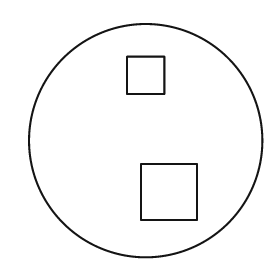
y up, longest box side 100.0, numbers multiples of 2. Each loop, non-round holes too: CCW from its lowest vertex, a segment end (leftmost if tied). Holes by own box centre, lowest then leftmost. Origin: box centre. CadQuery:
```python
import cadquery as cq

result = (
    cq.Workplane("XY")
    .moveTo(0.0, 0.0)
    .circle(50.0)
    .moveTo(-2.0, -34.0)
    .lineTo(22.0, -34.0)
    .lineTo(22.0, -10.0)
    .lineTo(-2.0, -10.0)
    .close()
    .moveTo(-8.0, 20.0)
    .lineTo(8.0, 20.0)
    .lineTo(8.0, 36.0)
    .lineTo(-8.0, 36.0)
    .close()
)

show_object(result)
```